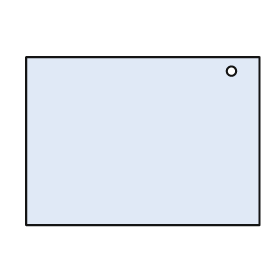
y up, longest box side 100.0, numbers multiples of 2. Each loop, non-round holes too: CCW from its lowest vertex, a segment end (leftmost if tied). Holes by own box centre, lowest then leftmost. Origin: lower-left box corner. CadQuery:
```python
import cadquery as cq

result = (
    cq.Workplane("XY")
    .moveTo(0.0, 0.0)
    .lineTo(100.0, 0.0)
    .lineTo(100.0, 72.0)
    .lineTo(0.0, 72.0)
    .close()
    .moveTo(88.0, 66.0)
    .circle(2.0)
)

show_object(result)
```